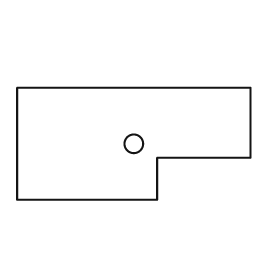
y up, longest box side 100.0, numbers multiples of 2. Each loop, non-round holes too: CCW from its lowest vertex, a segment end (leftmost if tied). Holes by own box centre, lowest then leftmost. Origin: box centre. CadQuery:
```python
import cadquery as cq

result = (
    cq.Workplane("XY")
    .moveTo(-50.0, -24.0)
    .lineTo(10.0, -24.0)
    .lineTo(10.0, -6.0)
    .lineTo(50.0, -6.0)
    .lineTo(50.0, 24.0)
    .lineTo(-50.0, 24.0)
    .close()
    .moveTo(0.0, 0.0)
    .circle(4.0)
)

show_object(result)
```